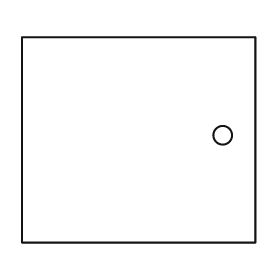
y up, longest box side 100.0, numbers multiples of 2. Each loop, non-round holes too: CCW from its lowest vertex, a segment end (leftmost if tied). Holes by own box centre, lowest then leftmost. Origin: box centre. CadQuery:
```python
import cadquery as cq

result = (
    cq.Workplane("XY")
    .moveTo(-50.0, -44.0)
    .lineTo(50.0, -44.0)
    .lineTo(50.0, 44.0)
    .lineTo(-50.0, 44.0)
    .close()
    .moveTo(36.0, 2.0)
    .circle(4.0)
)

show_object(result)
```